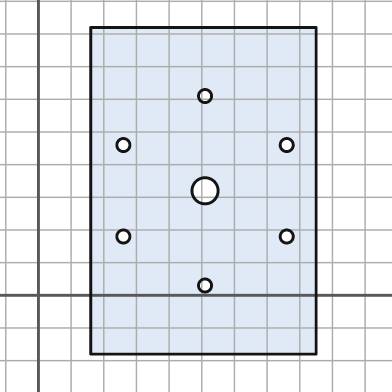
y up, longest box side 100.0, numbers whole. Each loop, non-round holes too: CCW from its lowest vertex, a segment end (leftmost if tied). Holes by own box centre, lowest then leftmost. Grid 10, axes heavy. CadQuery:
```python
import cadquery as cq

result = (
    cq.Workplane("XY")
    .moveTo(16.0, -18.0)
    .lineTo(85.0, -18.0)
    .lineTo(85.0, 82.0)
    .lineTo(16.0, 82.0)
    .close()
    .moveTo(51.0, 3.0)
    .circle(2.0)
    .moveTo(26.0, 18.0)
    .circle(2.0)
    .moveTo(76.0, 18.0)
    .circle(2.0)
    .moveTo(51.0, 32.0)
    .circle(4.0)
    .moveTo(26.0, 46.0)
    .circle(2.0)
    .moveTo(76.0, 46.0)
    .circle(2.0)
    .moveTo(51.0, 61.0)
    .circle(2.0)
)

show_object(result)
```